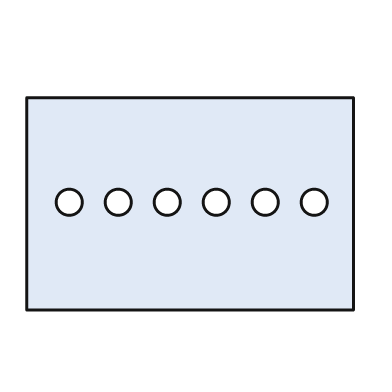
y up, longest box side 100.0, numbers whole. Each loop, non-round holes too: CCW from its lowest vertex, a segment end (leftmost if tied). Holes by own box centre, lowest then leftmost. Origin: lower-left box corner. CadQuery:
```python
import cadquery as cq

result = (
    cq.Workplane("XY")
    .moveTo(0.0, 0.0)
    .lineTo(100.0, 0.0)
    .lineTo(100.0, 65.0)
    .lineTo(0.0, 65.0)
    .close()
    .moveTo(13.0, 33.0)
    .circle(4.0)
    .moveTo(28.0, 33.0)
    .circle(4.0)
    .moveTo(43.0, 33.0)
    .circle(4.0)
    .moveTo(58.0, 33.0)
    .circle(4.0)
    .moveTo(73.0, 33.0)
    .circle(4.0)
    .moveTo(88.0, 33.0)
    .circle(4.0)
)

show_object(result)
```